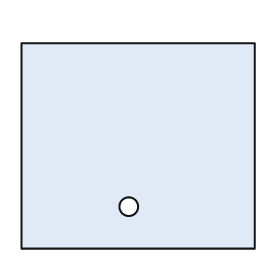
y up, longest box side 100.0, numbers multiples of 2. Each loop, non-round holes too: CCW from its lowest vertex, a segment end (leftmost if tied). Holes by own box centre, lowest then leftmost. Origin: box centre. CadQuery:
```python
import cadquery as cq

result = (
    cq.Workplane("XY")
    .moveTo(-50.0, -44.0)
    .lineTo(50.0, -44.0)
    .lineTo(50.0, 44.0)
    .lineTo(-50.0, 44.0)
    .close()
    .moveTo(-4.0, -26.0)
    .circle(4.0)
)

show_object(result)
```